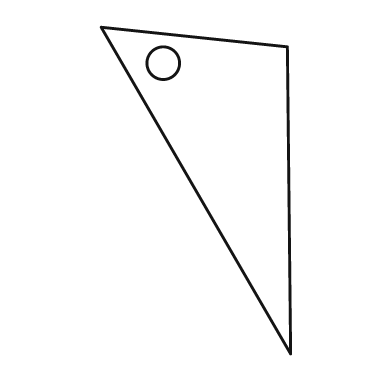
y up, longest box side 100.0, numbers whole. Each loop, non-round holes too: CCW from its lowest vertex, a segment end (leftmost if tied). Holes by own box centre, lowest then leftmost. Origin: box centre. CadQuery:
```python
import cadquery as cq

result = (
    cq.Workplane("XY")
    .moveTo(29.0, -50.0)
    .lineTo(28.0, 44.0)
    .lineTo(-29.0, 50.0)
    .close()
    .moveTo(-10.0, 39.0)
    .circle(5.0)
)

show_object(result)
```